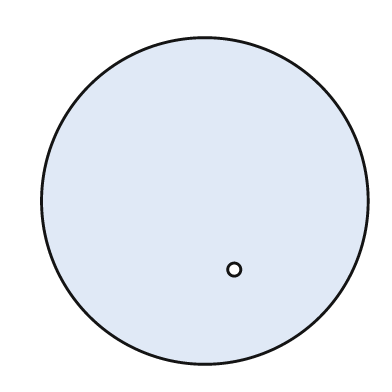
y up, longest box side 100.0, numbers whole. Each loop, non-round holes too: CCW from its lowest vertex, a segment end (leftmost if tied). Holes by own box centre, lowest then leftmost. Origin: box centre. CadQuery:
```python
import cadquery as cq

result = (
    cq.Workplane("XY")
    .moveTo(0.0, 0.0)
    .circle(50.0)
    .moveTo(9.0, -21.0)
    .circle(2.0)
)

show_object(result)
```